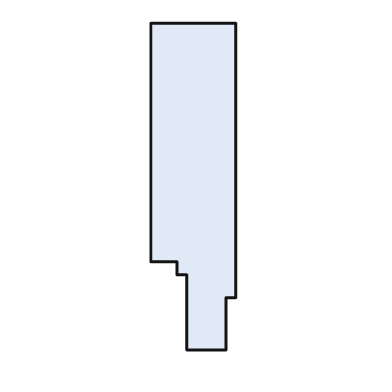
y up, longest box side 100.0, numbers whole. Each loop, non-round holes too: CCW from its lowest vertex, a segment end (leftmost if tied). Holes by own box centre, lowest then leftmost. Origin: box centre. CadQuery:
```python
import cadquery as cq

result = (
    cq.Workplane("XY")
    .moveTo(-2.0, -50.0)
    .lineTo(10.0, -50.0)
    .lineTo(10.0, -34.0)
    .lineTo(13.0, -34.0)
    .lineTo(13.0, 50.0)
    .lineTo(-13.0, 50.0)
    .lineTo(-13.0, -23.0)
    .lineTo(-5.0, -23.0)
    .lineTo(-5.0, -27.0)
    .lineTo(-2.0, -27.0)
    .close()
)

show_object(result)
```